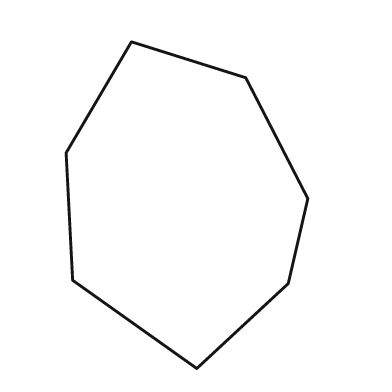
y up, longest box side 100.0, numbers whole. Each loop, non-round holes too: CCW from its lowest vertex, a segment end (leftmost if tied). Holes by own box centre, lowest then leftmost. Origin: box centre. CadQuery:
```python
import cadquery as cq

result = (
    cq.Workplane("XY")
    .moveTo(3.0, -50.0)
    .lineTo(31.0, -24.0)
    .lineTo(37.0, 2.0)
    .lineTo(18.0, 39.0)
    .lineTo(-17.0, 50.0)
    .lineTo(-37.0, 16.0)
    .lineTo(-35.0, -23.0)
    .close()
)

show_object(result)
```